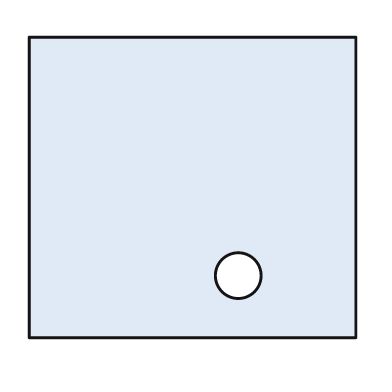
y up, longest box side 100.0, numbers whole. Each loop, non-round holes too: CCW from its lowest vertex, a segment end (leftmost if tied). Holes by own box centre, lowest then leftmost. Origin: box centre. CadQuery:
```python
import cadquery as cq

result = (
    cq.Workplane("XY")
    .moveTo(-50.0, -46.0)
    .lineTo(50.0, -46.0)
    .lineTo(50.0, 46.0)
    .lineTo(-50.0, 46.0)
    .close()
    .moveTo(14.0, -27.0)
    .circle(7.0)
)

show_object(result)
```